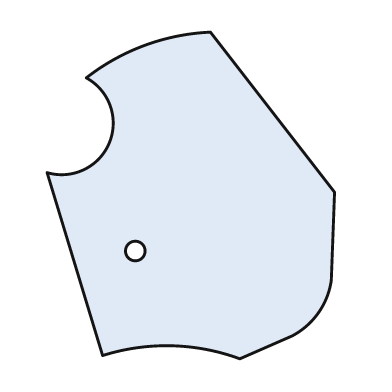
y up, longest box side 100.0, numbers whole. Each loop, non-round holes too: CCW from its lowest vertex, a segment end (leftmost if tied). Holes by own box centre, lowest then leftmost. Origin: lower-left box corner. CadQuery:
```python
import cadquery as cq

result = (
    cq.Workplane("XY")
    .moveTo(59.0, 0.0)
    .lineTo(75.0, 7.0)
    .threePointArc((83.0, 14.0), (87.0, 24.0))
    .lineTo(88.0, 51.0)
    .lineTo(50.0, 100.0)
    .threePointArc((30.0, 96.0), (12.0, 86.0))
    .threePointArc((19.0, 66.0), (0.0, 57.0))
    .lineTo(17.0, 1.0)
    .threePointArc((38.0, 4.0), (59.0, 0.0))
    .close()
    .moveTo(27.0, 33.0)
    .circle(3.0)
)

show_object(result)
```